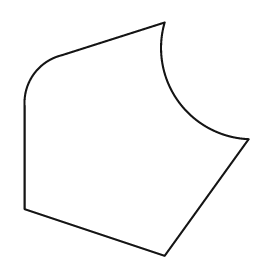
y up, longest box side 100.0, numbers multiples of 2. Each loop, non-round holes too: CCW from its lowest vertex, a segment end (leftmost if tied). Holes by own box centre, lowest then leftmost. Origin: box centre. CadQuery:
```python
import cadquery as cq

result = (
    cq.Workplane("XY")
    .moveTo(12.0, -50.0)
    .lineTo(48.0, 0.0)
    .threePointArc((18.0, 16.0), (12.0, 50.0))
    .lineTo(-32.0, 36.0)
    .threePointArc((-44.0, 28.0), (-48.0, 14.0))
    .lineTo(-48.0, -30.0)
    .close()
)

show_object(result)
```